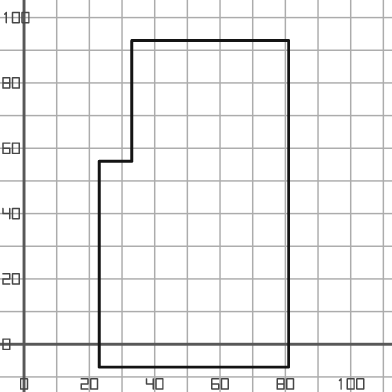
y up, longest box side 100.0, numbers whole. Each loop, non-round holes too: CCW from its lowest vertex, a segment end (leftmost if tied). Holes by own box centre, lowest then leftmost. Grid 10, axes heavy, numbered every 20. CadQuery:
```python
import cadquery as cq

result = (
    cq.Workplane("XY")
    .moveTo(23.0, -7.0)
    .lineTo(81.0, -7.0)
    .lineTo(81.0, 93.0)
    .lineTo(33.0, 93.0)
    .lineTo(33.0, 56.0)
    .lineTo(23.0, 56.0)
    .close()
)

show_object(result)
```